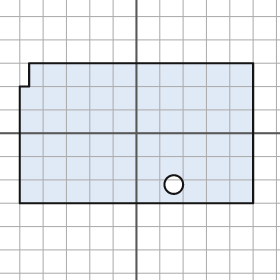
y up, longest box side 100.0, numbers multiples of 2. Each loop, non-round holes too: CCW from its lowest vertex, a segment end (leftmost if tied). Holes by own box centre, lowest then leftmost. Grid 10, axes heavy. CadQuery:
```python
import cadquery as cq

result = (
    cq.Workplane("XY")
    .moveTo(-50.0, -30.0)
    .lineTo(50.0, -30.0)
    .lineTo(50.0, 30.0)
    .lineTo(-46.0, 30.0)
    .lineTo(-46.0, 20.0)
    .lineTo(-50.0, 20.0)
    .close()
    .moveTo(16.0, -22.0)
    .circle(4.0)
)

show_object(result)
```